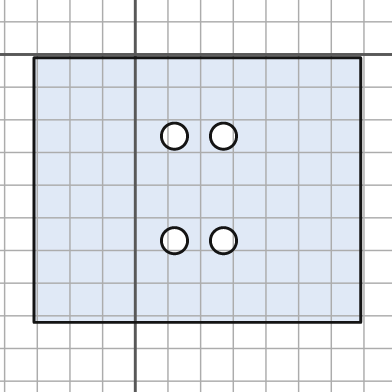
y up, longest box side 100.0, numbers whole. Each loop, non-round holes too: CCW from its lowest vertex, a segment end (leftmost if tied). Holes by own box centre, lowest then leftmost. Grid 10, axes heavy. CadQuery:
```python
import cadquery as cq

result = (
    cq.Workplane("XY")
    .moveTo(-31.0, -82.0)
    .lineTo(69.0, -82.0)
    .lineTo(69.0, -1.0)
    .lineTo(-31.0, -1.0)
    .close()
    .moveTo(12.0, -57.0)
    .circle(4.0)
    .moveTo(27.0, -57.0)
    .circle(4.0)
    .moveTo(12.0, -25.0)
    .circle(4.0)
    .moveTo(27.0, -25.0)
    .circle(4.0)
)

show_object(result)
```